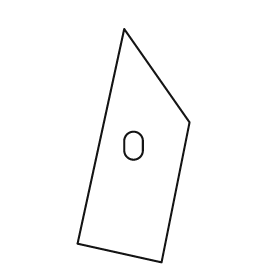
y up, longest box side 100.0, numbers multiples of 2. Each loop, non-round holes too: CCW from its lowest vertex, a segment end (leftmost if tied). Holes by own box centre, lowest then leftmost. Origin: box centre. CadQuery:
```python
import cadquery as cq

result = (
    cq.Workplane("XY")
    .moveTo(12.0, -50.0)
    .lineTo(24.0, 10.0)
    .lineTo(-4.0, 50.0)
    .lineTo(-24.0, -42.0)
    .close()
    .moveTo(-4.0, -2.0)
    .threePointArc((0.0, -6.0), (4.0, -2.0))
    .lineTo(4.0, 2.0)
    .threePointArc((0.0, 6.0), (-4.0, 2.0))
    .close()
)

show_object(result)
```